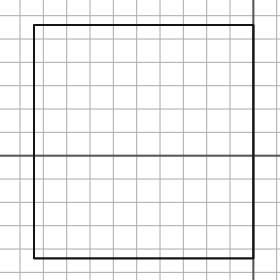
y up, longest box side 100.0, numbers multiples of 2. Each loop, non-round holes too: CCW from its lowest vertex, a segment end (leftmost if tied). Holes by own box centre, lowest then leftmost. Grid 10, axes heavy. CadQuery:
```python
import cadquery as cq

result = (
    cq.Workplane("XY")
    .moveTo(-94.0, -44.0)
    .lineTo(0.0, -44.0)
    .lineTo(0.0, 56.0)
    .lineTo(-94.0, 56.0)
    .close()
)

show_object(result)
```